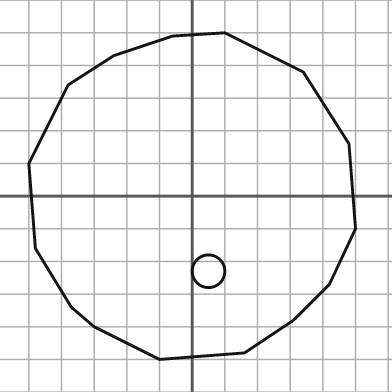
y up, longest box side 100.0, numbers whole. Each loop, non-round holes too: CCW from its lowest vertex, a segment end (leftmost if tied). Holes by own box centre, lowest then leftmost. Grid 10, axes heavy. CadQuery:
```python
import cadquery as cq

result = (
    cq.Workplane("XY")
    .moveTo(-10.0, -50.0)
    .lineTo(16.0, -48.0)
    .lineTo(31.0, -38.0)
    .lineTo(42.0, -27.0)
    .lineTo(50.0, -10.0)
    .lineTo(48.0, 16.0)
    .lineTo(34.0, 38.0)
    .lineTo(10.0, 50.0)
    .lineTo(-6.0, 49.0)
    .lineTo(-24.0, 43.0)
    .lineTo(-38.0, 34.0)
    .lineTo(-50.0, 10.0)
    .lineTo(-48.0, -16.0)
    .lineTo(-37.0, -34.0)
    .lineTo(-30.0, -40.0)
    .close()
    .moveTo(5.0, -23.0)
    .circle(5.0)
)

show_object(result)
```